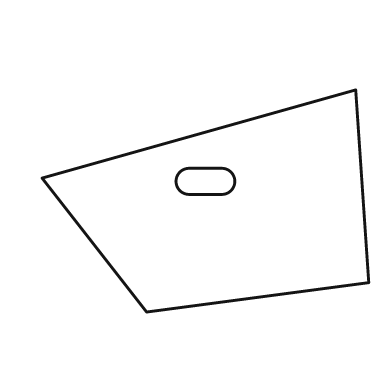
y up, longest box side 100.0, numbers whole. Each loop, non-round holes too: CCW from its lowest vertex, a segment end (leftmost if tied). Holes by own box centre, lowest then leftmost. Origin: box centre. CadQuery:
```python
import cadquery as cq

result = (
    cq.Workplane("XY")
    .moveTo(-18.0, -34.0)
    .lineTo(50.0, -25.0)
    .lineTo(46.0, 34.0)
    .lineTo(-50.0, 7.0)
    .close()
    .moveTo(-5.0, 2.0)
    .lineTo(5.0, 2.0)
    .threePointArc((9.0, 6.0), (5.0, 10.0))
    .lineTo(-5.0, 10.0)
    .threePointArc((-9.0, 6.0), (-5.0, 2.0))
    .close()
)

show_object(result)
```